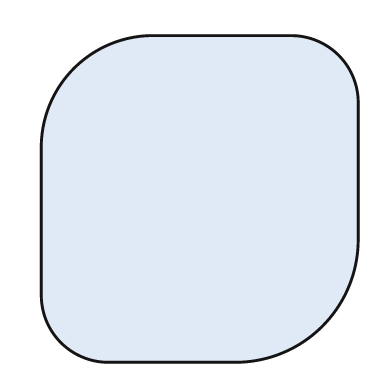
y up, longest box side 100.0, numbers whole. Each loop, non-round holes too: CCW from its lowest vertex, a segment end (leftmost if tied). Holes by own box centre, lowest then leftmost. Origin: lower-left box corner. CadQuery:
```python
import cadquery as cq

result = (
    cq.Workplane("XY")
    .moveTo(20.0, 0.0)
    .lineTo(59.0, 0.0)
    .threePointArc((86.0, 11.0), (97.0, 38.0))
    .lineTo(97.0, 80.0)
    .threePointArc((91.0, 94.0), (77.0, 100.0))
    .lineTo(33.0, 100.0)
    .threePointArc((10.0, 90.0), (0.0, 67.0))
    .lineTo(0.0, 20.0)
    .threePointArc((6.0, 6.0), (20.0, 0.0))
    .close()
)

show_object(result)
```